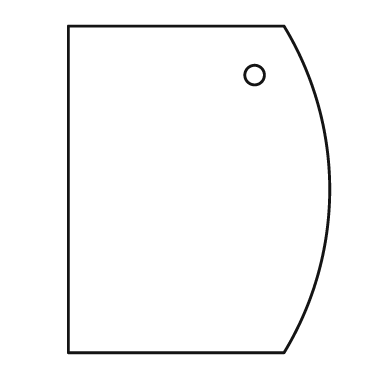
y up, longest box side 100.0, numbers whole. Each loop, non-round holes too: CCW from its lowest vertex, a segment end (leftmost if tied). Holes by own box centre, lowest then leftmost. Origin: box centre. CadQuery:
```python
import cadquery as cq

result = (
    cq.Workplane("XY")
    .moveTo(-40.0, -50.0)
    .lineTo(26.0, -50.0)
    .threePointArc((40.0, 0.0), (26.0, 50.0))
    .lineTo(-40.0, 50.0)
    .close()
    .moveTo(17.0, 35.0)
    .circle(3.0)
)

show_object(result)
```